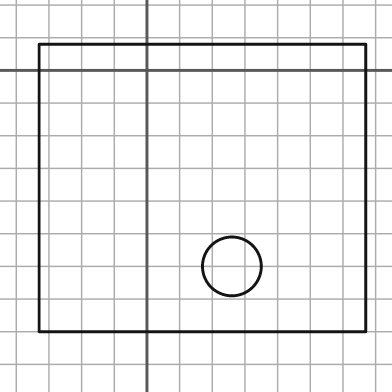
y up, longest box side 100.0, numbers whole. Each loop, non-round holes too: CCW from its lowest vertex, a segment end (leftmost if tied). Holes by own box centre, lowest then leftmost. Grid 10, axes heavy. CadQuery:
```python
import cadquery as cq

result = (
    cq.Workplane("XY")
    .moveTo(-33.0, -80.0)
    .lineTo(67.0, -80.0)
    .lineTo(67.0, 8.0)
    .lineTo(-33.0, 8.0)
    .close()
    .moveTo(26.0, -60.0)
    .circle(9.0)
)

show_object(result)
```